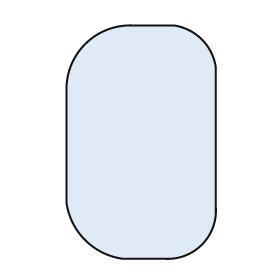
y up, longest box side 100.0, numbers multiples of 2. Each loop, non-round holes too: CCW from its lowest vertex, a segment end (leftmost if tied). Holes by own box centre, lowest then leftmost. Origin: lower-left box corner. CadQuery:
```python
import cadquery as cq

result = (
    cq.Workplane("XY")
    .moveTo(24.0, 0.0)
    .lineTo(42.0, 0.0)
    .threePointArc((58.0, 6.0), (64.0, 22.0))
    .lineTo(64.0, 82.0)
    .threePointArc((58.0, 94.0), (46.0, 100.0))
    .lineTo(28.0, 100.0)
    .threePointArc((8.0, 92.0), (0.0, 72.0))
    .lineTo(0.0, 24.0)
    .threePointArc((8.0, 8.0), (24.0, 0.0))
    .close()
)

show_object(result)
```